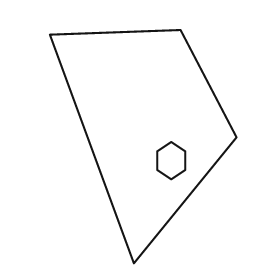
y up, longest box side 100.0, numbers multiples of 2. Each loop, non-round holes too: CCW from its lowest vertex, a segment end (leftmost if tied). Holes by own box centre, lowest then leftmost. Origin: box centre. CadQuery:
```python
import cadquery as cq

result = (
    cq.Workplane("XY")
    .moveTo(-4.0, -50.0)
    .lineTo(40.0, 4.0)
    .lineTo(16.0, 50.0)
    .lineTo(-40.0, 48.0)
    .close()
    .moveTo(12.0, -14.0)
    .lineTo(18.0, -10.0)
    .lineTo(18.0, -2.0)
    .lineTo(12.0, 2.0)
    .lineTo(6.0, -2.0)
    .lineTo(6.0, -10.0)
    .close()
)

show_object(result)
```